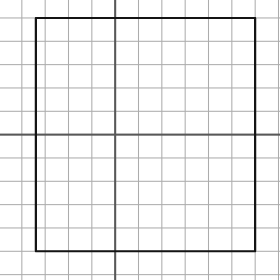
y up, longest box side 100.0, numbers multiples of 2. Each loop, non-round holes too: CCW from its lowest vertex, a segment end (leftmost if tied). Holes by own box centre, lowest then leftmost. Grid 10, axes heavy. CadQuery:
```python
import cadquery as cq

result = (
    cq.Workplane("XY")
    .moveTo(-34.0, -50.0)
    .lineTo(60.0, -50.0)
    .lineTo(60.0, 50.0)
    .lineTo(-34.0, 50.0)
    .close()
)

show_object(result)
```